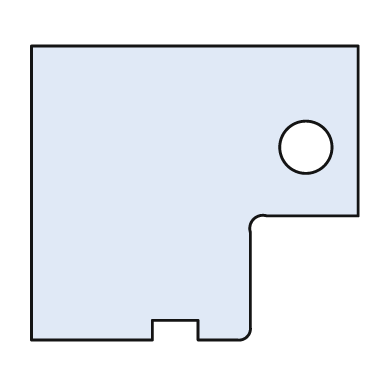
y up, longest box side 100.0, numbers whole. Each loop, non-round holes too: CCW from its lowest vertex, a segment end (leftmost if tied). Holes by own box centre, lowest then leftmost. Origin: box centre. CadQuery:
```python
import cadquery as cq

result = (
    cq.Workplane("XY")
    .moveTo(-50.0, -45.0)
    .lineTo(-13.0, -45.0)
    .lineTo(-13.0, -39.0)
    .lineTo(1.0, -39.0)
    .lineTo(1.0, -45.0)
    .lineTo(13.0, -45.0)
    .threePointArc((16.0, -44.0), (17.0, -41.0))
    .lineTo(17.0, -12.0)
    .threePointArc((18.0, -8.0), (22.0, -7.0))
    .lineTo(50.0, -7.0)
    .lineTo(50.0, 45.0)
    .lineTo(-50.0, 45.0)
    .close()
    .moveTo(34.0, 14.0)
    .circle(8.0)
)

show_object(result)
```